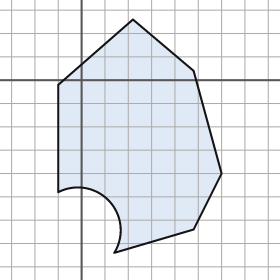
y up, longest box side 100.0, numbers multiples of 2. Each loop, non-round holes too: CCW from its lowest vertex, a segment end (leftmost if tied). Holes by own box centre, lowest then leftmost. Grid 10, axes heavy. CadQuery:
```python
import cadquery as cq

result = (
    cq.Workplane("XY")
    .moveTo(14.0, -74.0)
    .lineTo(48.0, -64.0)
    .lineTo(60.0, -40.0)
    .lineTo(48.0, 4.0)
    .lineTo(22.0, 26.0)
    .lineTo(-10.0, -2.0)
    .lineTo(-10.0, -48.0)
    .threePointArc((12.0, -52.0), (14.0, -74.0))
    .close()
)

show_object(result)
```